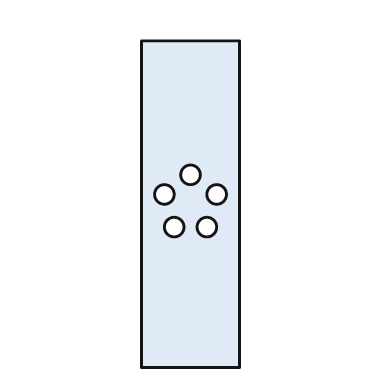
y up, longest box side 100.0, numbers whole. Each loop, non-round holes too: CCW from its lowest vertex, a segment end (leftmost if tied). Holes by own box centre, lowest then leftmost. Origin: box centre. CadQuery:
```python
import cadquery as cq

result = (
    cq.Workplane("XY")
    .moveTo(-15.0, -50.0)
    .lineTo(15.0, -50.0)
    .lineTo(15.0, 50.0)
    .lineTo(-15.0, 50.0)
    .close()
    .moveTo(-5.0, -7.0)
    .circle(3.0)
    .moveTo(5.0, -7.0)
    .circle(3.0)
    .moveTo(-8.0, 3.0)
    .circle(3.0)
    .moveTo(8.0, 3.0)
    .circle(3.0)
    .moveTo(0.0, 9.0)
    .circle(3.0)
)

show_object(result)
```